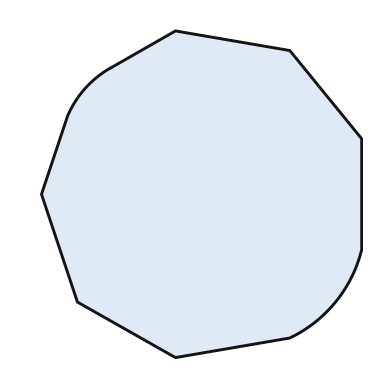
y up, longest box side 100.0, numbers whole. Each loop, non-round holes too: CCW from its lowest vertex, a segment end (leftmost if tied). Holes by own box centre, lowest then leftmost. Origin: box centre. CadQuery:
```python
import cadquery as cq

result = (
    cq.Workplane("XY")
    .moveTo(-8.0, -50.0)
    .lineTo(27.0, -44.0)
    .threePointArc((41.0, -33.0), (49.0, -17.0))
    .lineTo(49.0, 17.0)
    .lineTo(27.0, 44.0)
    .lineTo(-8.0, 50.0)
    .lineTo(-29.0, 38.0)
    .threePointArc((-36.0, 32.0), (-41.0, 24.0))
    .lineTo(-49.0, 0.0)
    .lineTo(-38.0, -33.0)
    .close()
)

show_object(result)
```